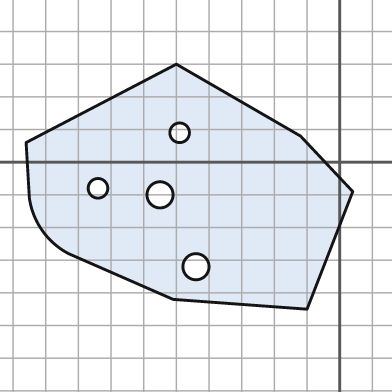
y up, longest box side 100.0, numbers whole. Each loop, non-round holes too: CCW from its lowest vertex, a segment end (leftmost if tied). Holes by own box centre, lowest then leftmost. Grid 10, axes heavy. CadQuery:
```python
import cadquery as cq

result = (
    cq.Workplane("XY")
    .moveTo(-10.0, -45.0)
    .lineTo(4.0, -9.0)
    .lineTo(-12.0, 8.0)
    .lineTo(-50.0, 30.0)
    .lineTo(-96.0, 6.0)
    .lineTo(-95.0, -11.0)
    .threePointArc((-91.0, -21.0), (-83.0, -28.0))
    .lineTo(-51.0, -42.0)
    .close()
    .moveTo(-44.0, -32.0)
    .circle(4.0)
    .moveTo(-55.0, -10.0)
    .circle(4.0)
    .moveTo(-74.0, -8.0)
    .circle(3.0)
    .moveTo(-49.0, 9.0)
    .circle(3.0)
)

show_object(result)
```